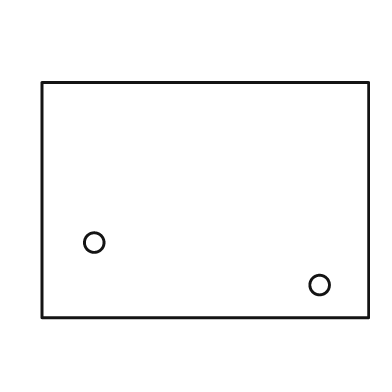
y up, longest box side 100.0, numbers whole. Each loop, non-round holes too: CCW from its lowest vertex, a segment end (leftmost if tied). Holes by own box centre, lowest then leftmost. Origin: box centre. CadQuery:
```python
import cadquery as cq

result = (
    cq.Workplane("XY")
    .moveTo(-50.0, -36.0)
    .lineTo(50.0, -36.0)
    .lineTo(50.0, 36.0)
    .lineTo(-50.0, 36.0)
    .close()
    .moveTo(35.0, -26.0)
    .circle(3.0)
    .moveTo(-34.0, -13.0)
    .circle(3.0)
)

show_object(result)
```